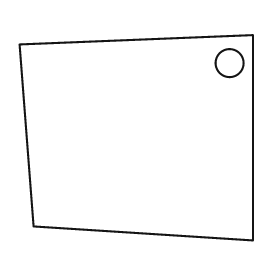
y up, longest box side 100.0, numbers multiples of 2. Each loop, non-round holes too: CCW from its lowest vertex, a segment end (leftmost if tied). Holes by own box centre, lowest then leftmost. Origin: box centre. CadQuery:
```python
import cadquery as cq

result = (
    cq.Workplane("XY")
    .moveTo(50.0, -44.0)
    .lineTo(50.0, 44.0)
    .lineTo(-50.0, 40.0)
    .lineTo(-44.0, -38.0)
    .close()
    .moveTo(40.0, 32.0)
    .circle(6.0)
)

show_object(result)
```